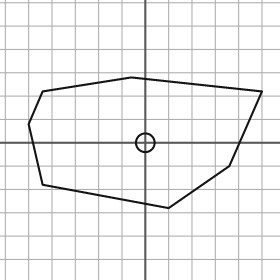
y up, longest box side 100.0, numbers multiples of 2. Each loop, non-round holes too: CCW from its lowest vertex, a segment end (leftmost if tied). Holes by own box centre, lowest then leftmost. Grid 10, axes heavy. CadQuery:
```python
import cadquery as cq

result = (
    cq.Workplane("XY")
    .moveTo(10.0, -28.0)
    .lineTo(36.0, -10.0)
    .lineTo(50.0, 22.0)
    .lineTo(-6.0, 28.0)
    .lineTo(-44.0, 22.0)
    .lineTo(-50.0, 8.0)
    .lineTo(-44.0, -18.0)
    .close()
    .moveTo(0.0, 0.0)
    .circle(4.0)
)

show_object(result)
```